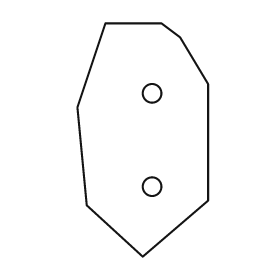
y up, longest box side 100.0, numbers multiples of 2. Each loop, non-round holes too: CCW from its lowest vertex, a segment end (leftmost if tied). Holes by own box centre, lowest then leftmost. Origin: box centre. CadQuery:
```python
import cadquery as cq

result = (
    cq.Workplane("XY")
    .moveTo(0.0, -50.0)
    .lineTo(28.0, -26.0)
    .lineTo(28.0, 24.0)
    .lineTo(16.0, 44.0)
    .lineTo(8.0, 50.0)
    .lineTo(-16.0, 50.0)
    .lineTo(-28.0, 14.0)
    .lineTo(-24.0, -28.0)
    .close()
    .moveTo(4.0, -20.0)
    .circle(4.0)
    .moveTo(4.0, 20.0)
    .circle(4.0)
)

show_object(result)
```